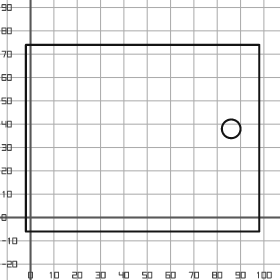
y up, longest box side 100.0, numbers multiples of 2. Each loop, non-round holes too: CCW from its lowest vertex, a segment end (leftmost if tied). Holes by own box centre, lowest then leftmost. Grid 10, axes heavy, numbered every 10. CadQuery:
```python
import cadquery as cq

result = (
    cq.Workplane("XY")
    .moveTo(-2.0, -6.0)
    .lineTo(98.0, -6.0)
    .lineTo(98.0, 74.0)
    .lineTo(-2.0, 74.0)
    .close()
    .moveTo(86.0, 38.0)
    .circle(4.0)
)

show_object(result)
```